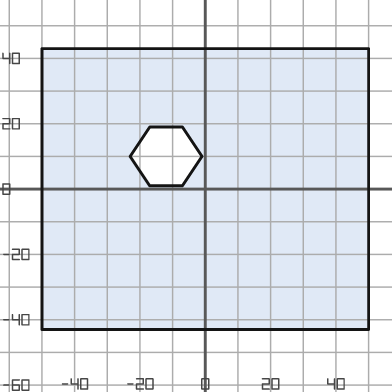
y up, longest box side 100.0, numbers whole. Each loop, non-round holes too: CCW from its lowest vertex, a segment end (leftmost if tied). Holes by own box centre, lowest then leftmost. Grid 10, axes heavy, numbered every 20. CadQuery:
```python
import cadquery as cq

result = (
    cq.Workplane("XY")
    .moveTo(-50.0, -43.0)
    .lineTo(50.0, -43.0)
    .lineTo(50.0, 43.0)
    .lineTo(-50.0, 43.0)
    .close()
    .moveTo(-17.0, 1.0)
    .lineTo(-7.0, 1.0)
    .lineTo(-1.0, 10.0)
    .lineTo(-7.0, 19.0)
    .lineTo(-17.0, 19.0)
    .lineTo(-23.0, 10.0)
    .close()
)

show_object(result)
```